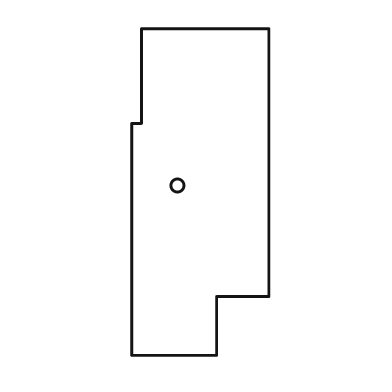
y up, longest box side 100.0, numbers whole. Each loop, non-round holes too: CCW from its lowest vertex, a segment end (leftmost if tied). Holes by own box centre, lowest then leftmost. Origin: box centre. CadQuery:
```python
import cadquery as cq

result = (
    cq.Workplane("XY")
    .moveTo(-21.0, -50.0)
    .lineTo(5.0, -50.0)
    .lineTo(5.0, -32.0)
    .lineTo(21.0, -32.0)
    .lineTo(21.0, 50.0)
    .lineTo(-18.0, 50.0)
    .lineTo(-18.0, 21.0)
    .lineTo(-21.0, 21.0)
    .close()
    .moveTo(-7.0, 2.0)
    .circle(2.0)
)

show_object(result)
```